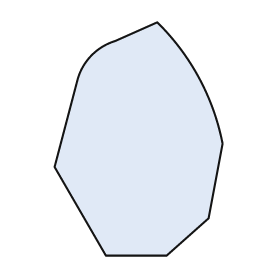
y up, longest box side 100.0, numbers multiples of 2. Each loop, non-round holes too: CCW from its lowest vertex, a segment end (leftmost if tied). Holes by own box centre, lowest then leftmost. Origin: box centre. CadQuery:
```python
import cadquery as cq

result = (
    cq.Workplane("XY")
    .moveTo(-14.0, -50.0)
    .lineTo(12.0, -50.0)
    .lineTo(30.0, -34.0)
    .lineTo(36.0, -2.0)
    .threePointArc((26.0, 26.0), (8.0, 50.0))
    .lineTo(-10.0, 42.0)
    .threePointArc((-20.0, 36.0), (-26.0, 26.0))
    .lineTo(-36.0, -12.0)
    .close()
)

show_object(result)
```